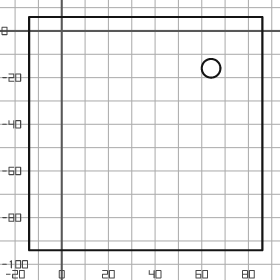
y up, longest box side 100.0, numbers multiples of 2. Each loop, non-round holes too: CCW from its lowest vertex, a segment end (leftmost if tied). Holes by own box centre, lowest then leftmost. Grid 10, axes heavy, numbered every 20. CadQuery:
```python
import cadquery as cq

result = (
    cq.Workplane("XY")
    .moveTo(-14.0, -94.0)
    .lineTo(86.0, -94.0)
    .lineTo(86.0, 6.0)
    .lineTo(-14.0, 6.0)
    .close()
    .moveTo(64.0, -16.0)
    .circle(4.0)
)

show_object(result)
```